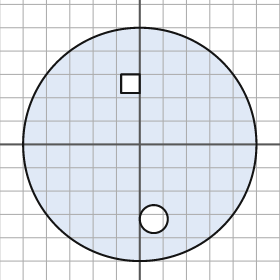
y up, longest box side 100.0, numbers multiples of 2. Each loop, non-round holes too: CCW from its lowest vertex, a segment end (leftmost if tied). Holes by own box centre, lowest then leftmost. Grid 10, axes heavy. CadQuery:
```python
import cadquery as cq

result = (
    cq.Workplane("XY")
    .moveTo(0.0, 0.0)
    .circle(50.0)
    .moveTo(6.0, -32.0)
    .circle(6.0)
    .moveTo(-8.0, 22.0)
    .lineTo(0.0, 22.0)
    .lineTo(0.0, 30.0)
    .lineTo(-8.0, 30.0)
    .close()
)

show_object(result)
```